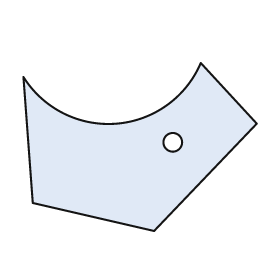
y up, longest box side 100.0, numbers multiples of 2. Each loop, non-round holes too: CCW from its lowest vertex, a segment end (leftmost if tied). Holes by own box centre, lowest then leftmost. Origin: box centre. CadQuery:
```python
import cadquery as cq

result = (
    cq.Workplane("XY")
    .moveTo(6.0, -36.0)
    .lineTo(50.0, 10.0)
    .lineTo(26.0, 36.0)
    .threePointArc((-10.0, 10.0), (-50.0, 30.0))
    .lineTo(-46.0, -24.0)
    .close()
    .moveTo(14.0, 2.0)
    .circle(4.0)
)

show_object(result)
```